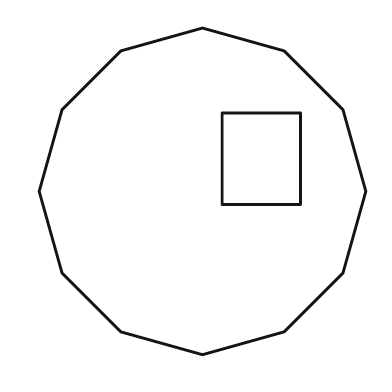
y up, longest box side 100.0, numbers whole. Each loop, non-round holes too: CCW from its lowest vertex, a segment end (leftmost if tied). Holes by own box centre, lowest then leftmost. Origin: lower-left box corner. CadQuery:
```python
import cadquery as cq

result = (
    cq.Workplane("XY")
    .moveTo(50.0, 0.0)
    .lineTo(75.0, 7.0)
    .lineTo(93.0, 25.0)
    .lineTo(100.0, 50.0)
    .lineTo(93.0, 75.0)
    .lineTo(75.0, 93.0)
    .lineTo(50.0, 100.0)
    .lineTo(25.0, 93.0)
    .lineTo(7.0, 75.0)
    .lineTo(0.0, 50.0)
    .lineTo(7.0, 25.0)
    .lineTo(25.0, 7.0)
    .close()
    .moveTo(56.0, 46.0)
    .lineTo(80.0, 46.0)
    .lineTo(80.0, 74.0)
    .lineTo(56.0, 74.0)
    .close()
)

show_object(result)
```